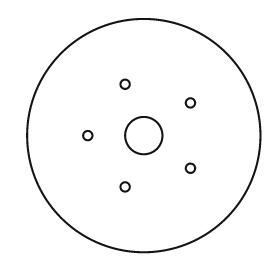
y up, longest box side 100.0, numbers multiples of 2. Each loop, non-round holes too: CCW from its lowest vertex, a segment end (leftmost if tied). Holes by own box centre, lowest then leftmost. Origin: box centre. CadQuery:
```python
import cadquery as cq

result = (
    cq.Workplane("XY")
    .moveTo(0.0, 0.0)
    .circle(50.0)
    .moveTo(-8.0, -22.0)
    .circle(2.0)
    .moveTo(20.0, -14.0)
    .circle(2.0)
    .moveTo(-24.0, 0.0)
    .circle(2.0)
    .moveTo(0.0, 0.0)
    .circle(8.0)
    .moveTo(20.0, 14.0)
    .circle(2.0)
    .moveTo(-8.0, 22.0)
    .circle(2.0)
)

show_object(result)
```